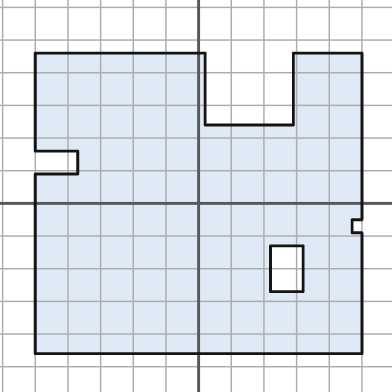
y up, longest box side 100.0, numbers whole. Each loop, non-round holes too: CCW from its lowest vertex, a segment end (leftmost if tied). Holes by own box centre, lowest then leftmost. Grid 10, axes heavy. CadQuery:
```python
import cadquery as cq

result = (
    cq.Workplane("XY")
    .moveTo(-50.0, -46.0)
    .lineTo(50.0, -46.0)
    .lineTo(50.0, -9.0)
    .lineTo(47.0, -9.0)
    .lineTo(47.0, -5.0)
    .lineTo(50.0, -5.0)
    .lineTo(50.0, 46.0)
    .lineTo(29.0, 46.0)
    .lineTo(29.0, 24.0)
    .lineTo(2.0, 24.0)
    .lineTo(2.0, 46.0)
    .lineTo(-50.0, 46.0)
    .lineTo(-50.0, 16.0)
    .lineTo(-37.0, 16.0)
    .lineTo(-37.0, 9.0)
    .lineTo(-50.0, 9.0)
    .close()
    .moveTo(22.0, -27.0)
    .lineTo(32.0, -27.0)
    .lineTo(32.0, -13.0)
    .lineTo(22.0, -13.0)
    .close()
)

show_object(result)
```